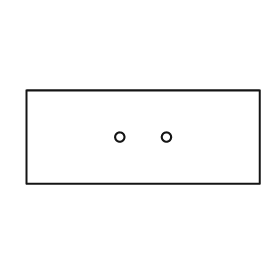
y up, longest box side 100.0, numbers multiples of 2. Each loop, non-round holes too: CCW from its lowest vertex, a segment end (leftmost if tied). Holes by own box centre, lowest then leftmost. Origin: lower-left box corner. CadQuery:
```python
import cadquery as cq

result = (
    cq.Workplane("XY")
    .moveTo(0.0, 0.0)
    .lineTo(100.0, 0.0)
    .lineTo(100.0, 40.0)
    .lineTo(0.0, 40.0)
    .close()
    .moveTo(40.0, 20.0)
    .circle(2.0)
    .moveTo(60.0, 20.0)
    .circle(2.0)
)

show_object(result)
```